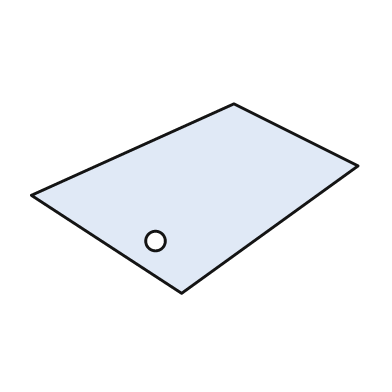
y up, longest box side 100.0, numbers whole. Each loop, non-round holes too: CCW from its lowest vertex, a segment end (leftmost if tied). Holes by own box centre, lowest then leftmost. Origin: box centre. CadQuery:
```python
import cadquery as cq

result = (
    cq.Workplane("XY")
    .moveTo(-4.0, -29.0)
    .lineTo(50.0, 10.0)
    .lineTo(12.0, 29.0)
    .lineTo(-50.0, 1.0)
    .close()
    .moveTo(-12.0, -13.0)
    .circle(3.0)
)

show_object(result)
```